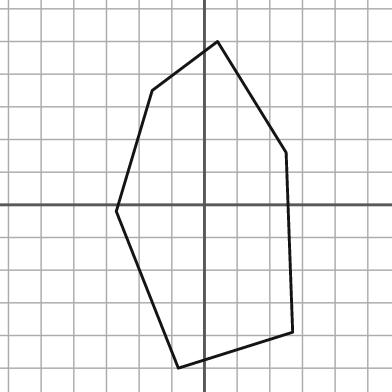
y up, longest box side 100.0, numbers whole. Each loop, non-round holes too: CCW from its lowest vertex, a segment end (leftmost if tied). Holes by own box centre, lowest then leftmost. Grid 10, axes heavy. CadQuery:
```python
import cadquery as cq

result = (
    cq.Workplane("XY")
    .moveTo(-8.0, -50.0)
    .lineTo(27.0, -39.0)
    .lineTo(25.0, 16.0)
    .lineTo(4.0, 50.0)
    .lineTo(-16.0, 35.0)
    .lineTo(-27.0, -2.0)
    .close()
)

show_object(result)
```